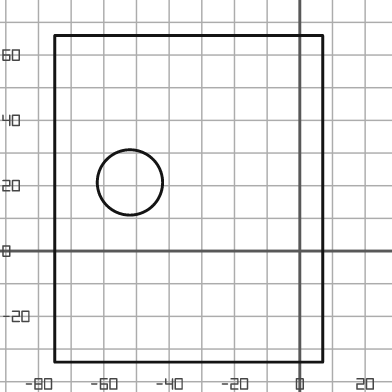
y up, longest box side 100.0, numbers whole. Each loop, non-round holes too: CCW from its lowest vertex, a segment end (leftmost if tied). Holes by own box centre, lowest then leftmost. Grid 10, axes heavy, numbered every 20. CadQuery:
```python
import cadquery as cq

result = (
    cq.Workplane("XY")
    .moveTo(-75.0, -34.0)
    .lineTo(7.0, -34.0)
    .lineTo(7.0, 66.0)
    .lineTo(-75.0, 66.0)
    .close()
    .moveTo(-52.0, 21.0)
    .circle(10.0)
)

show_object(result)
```